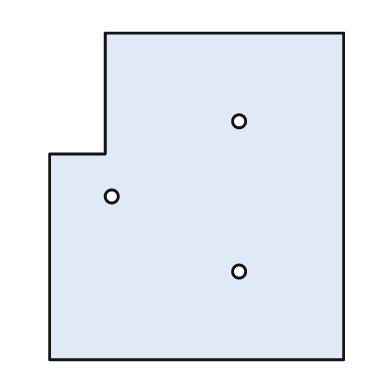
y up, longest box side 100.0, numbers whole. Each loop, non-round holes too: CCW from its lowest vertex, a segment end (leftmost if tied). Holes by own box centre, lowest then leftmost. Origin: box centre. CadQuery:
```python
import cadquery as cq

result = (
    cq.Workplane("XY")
    .moveTo(-45.0, -50.0)
    .lineTo(45.0, -50.0)
    .lineTo(45.0, 50.0)
    .lineTo(-28.0, 50.0)
    .lineTo(-28.0, 13.0)
    .lineTo(-45.0, 13.0)
    .close()
    .moveTo(13.0, -23.0)
    .circle(2.0)
    .moveTo(-26.0, 0.0)
    .circle(2.0)
    .moveTo(13.0, 23.0)
    .circle(2.0)
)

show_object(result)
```